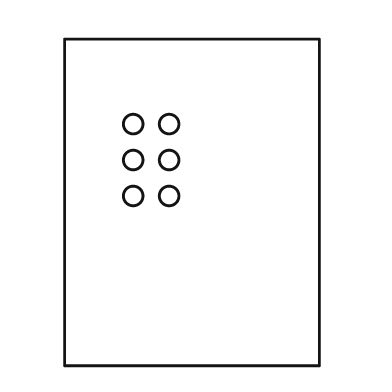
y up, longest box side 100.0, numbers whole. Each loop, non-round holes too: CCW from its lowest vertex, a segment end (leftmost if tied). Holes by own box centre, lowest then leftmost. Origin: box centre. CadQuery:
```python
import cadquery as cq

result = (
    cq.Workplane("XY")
    .moveTo(-39.0, -50.0)
    .lineTo(39.0, -50.0)
    .lineTo(39.0, 50.0)
    .lineTo(-39.0, 50.0)
    .close()
    .moveTo(-18.0, 2.0)
    .circle(3.0)
    .moveTo(-7.0, 2.0)
    .circle(3.0)
    .moveTo(-18.0, 13.0)
    .circle(3.0)
    .moveTo(-7.0, 13.0)
    .circle(3.0)
    .moveTo(-18.0, 24.0)
    .circle(3.0)
    .moveTo(-7.0, 24.0)
    .circle(3.0)
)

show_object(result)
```